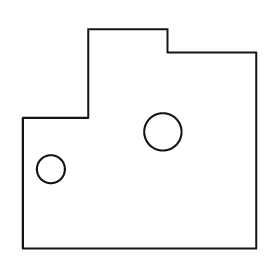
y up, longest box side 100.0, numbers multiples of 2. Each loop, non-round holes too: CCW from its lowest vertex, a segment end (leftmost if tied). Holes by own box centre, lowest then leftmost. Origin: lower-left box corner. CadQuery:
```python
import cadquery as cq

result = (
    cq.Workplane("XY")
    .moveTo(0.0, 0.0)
    .lineTo(100.0, 0.0)
    .lineTo(100.0, 84.0)
    .lineTo(62.0, 84.0)
    .lineTo(62.0, 94.0)
    .lineTo(28.0, 94.0)
    .lineTo(28.0, 56.0)
    .lineTo(0.0, 56.0)
    .close()
    .moveTo(12.0, 34.0)
    .circle(6.0)
    .moveTo(60.0, 50.0)
    .circle(8.0)
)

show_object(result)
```